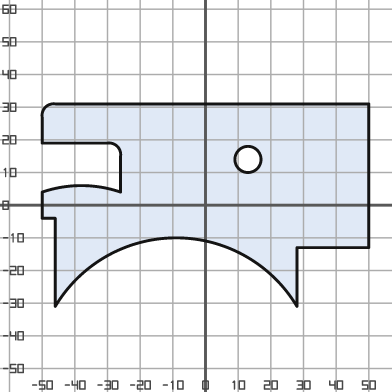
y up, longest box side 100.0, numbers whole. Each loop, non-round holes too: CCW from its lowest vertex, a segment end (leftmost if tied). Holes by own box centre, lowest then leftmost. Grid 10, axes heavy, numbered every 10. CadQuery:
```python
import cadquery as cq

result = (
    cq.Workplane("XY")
    .moveTo(-46.0, -31.0)
    .threePointArc((-9.0, -10.0), (28.0, -31.0))
    .lineTo(28.0, -13.0)
    .lineTo(50.0, -13.0)
    .lineTo(50.0, 31.0)
    .lineTo(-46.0, 31.0)
    .threePointArc((-49.0, 30.0), (-50.0, 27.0))
    .lineTo(-50.0, 19.0)
    .lineTo(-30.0, 19.0)
    .threePointArc((-27.0, 18.0), (-26.0, 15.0))
    .lineTo(-26.0, 4.0)
    .threePointArc((-38.0, 6.0), (-50.0, 4.0))
    .lineTo(-50.0, -4.0)
    .lineTo(-46.0, -4.0)
    .close()
    .moveTo(13.0, 14.0)
    .circle(4.0)
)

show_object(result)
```